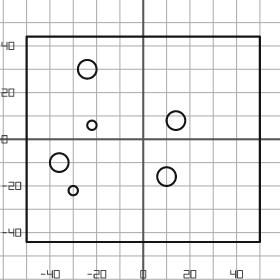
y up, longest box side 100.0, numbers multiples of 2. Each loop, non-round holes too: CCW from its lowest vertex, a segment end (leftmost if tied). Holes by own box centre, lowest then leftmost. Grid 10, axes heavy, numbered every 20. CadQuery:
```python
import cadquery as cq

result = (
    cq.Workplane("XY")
    .moveTo(-50.0, -44.0)
    .lineTo(50.0, -44.0)
    .lineTo(50.0, 44.0)
    .lineTo(-50.0, 44.0)
    .close()
    .moveTo(-30.0, -22.0)
    .circle(2.0)
    .moveTo(10.0, -16.0)
    .circle(4.0)
    .moveTo(-36.0, -10.0)
    .circle(4.0)
    .moveTo(-22.0, 6.0)
    .circle(2.0)
    .moveTo(14.0, 8.0)
    .circle(4.0)
    .moveTo(-24.0, 30.0)
    .circle(4.0)
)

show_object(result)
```